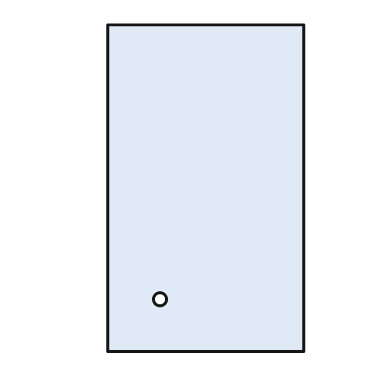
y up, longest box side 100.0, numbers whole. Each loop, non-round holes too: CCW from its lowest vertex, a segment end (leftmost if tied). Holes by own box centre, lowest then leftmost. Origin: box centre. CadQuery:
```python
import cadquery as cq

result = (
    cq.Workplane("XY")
    .moveTo(-30.0, -50.0)
    .lineTo(30.0, -50.0)
    .lineTo(30.0, 50.0)
    .lineTo(-30.0, 50.0)
    .close()
    .moveTo(-14.0, -34.0)
    .circle(2.0)
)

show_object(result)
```